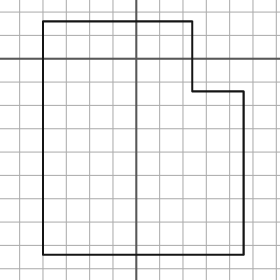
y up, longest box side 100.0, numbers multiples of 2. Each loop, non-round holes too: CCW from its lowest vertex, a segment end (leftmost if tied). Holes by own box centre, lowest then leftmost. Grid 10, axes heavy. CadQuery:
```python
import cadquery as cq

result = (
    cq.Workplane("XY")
    .moveTo(-40.0, -84.0)
    .lineTo(46.0, -84.0)
    .lineTo(46.0, -14.0)
    .lineTo(24.0, -14.0)
    .lineTo(24.0, 16.0)
    .lineTo(-40.0, 16.0)
    .close()
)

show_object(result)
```